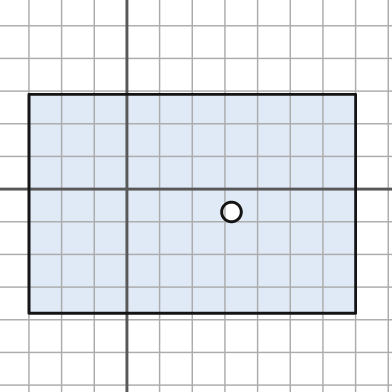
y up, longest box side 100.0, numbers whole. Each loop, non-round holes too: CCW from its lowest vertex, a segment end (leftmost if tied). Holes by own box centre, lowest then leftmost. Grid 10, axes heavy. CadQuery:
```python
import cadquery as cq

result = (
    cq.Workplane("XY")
    .moveTo(-30.0, -38.0)
    .lineTo(70.0, -38.0)
    .lineTo(70.0, 29.0)
    .lineTo(-30.0, 29.0)
    .close()
    .moveTo(32.0, -7.0)
    .circle(3.0)
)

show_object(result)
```